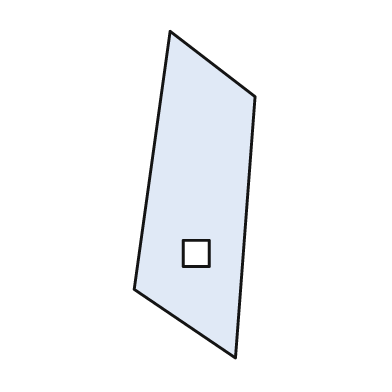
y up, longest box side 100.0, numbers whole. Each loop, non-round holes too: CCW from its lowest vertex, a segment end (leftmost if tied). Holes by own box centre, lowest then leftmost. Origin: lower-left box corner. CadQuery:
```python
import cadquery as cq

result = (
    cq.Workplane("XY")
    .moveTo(31.0, 0.0)
    .lineTo(37.0, 80.0)
    .lineTo(11.0, 100.0)
    .lineTo(0.0, 21.0)
    .close()
    .moveTo(15.0, 28.0)
    .lineTo(23.0, 28.0)
    .lineTo(23.0, 36.0)
    .lineTo(15.0, 36.0)
    .close()
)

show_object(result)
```